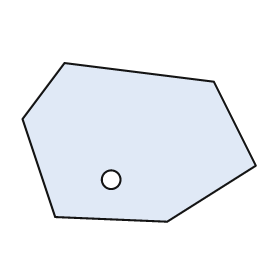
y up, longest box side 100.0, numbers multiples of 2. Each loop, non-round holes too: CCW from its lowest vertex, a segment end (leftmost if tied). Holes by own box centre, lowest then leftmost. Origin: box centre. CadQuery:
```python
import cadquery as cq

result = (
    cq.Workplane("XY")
    .moveTo(12.0, -34.0)
    .lineTo(50.0, -10.0)
    .lineTo(32.0, 26.0)
    .lineTo(-32.0, 34.0)
    .lineTo(-50.0, 10.0)
    .lineTo(-36.0, -32.0)
    .close()
    .moveTo(-12.0, -16.0)
    .circle(4.0)
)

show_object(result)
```